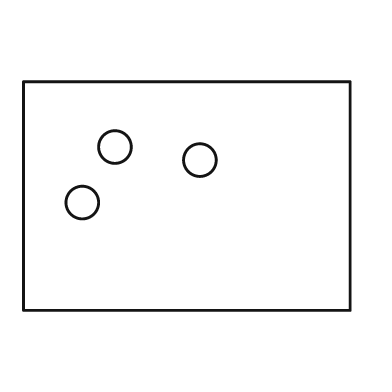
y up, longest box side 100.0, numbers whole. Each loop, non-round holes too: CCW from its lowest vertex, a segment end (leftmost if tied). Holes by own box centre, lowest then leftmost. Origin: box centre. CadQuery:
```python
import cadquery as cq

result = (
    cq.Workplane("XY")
    .moveTo(-50.0, -35.0)
    .lineTo(50.0, -35.0)
    .lineTo(50.0, 35.0)
    .lineTo(-50.0, 35.0)
    .close()
    .moveTo(-32.0, -2.0)
    .circle(5.0)
    .moveTo(4.0, 11.0)
    .circle(5.0)
    .moveTo(-22.0, 15.0)
    .circle(5.0)
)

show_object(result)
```